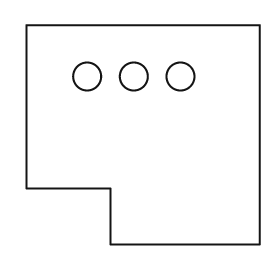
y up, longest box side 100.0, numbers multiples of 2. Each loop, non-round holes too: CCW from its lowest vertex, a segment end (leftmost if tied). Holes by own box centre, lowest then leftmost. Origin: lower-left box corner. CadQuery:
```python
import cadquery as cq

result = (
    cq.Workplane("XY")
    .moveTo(36.0, 0.0)
    .lineTo(100.0, 0.0)
    .lineTo(100.0, 94.0)
    .lineTo(0.0, 94.0)
    .lineTo(0.0, 24.0)
    .lineTo(36.0, 24.0)
    .close()
    .moveTo(26.0, 72.0)
    .circle(6.0)
    .moveTo(46.0, 72.0)
    .circle(6.0)
    .moveTo(66.0, 72.0)
    .circle(6.0)
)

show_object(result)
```